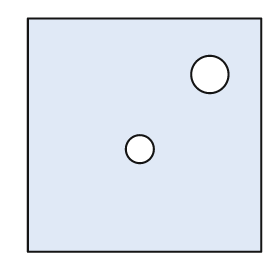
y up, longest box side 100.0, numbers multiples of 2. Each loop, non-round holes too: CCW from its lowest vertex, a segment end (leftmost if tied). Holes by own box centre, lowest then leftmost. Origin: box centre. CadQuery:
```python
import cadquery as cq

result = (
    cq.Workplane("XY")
    .moveTo(-50.0, -50.0)
    .lineTo(50.0, -50.0)
    .lineTo(50.0, 50.0)
    .lineTo(-50.0, 50.0)
    .close()
    .moveTo(-2.0, -6.0)
    .circle(6.0)
    .moveTo(28.0, 26.0)
    .circle(8.0)
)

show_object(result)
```